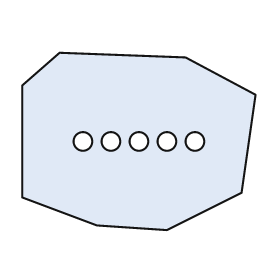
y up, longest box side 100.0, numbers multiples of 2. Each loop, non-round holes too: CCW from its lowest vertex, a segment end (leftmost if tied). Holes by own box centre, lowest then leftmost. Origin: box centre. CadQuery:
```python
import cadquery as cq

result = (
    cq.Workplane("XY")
    .moveTo(12.0, -38.0)
    .lineTo(44.0, -22.0)
    .lineTo(50.0, 20.0)
    .lineTo(20.0, 36.0)
    .lineTo(-34.0, 38.0)
    .lineTo(-50.0, 24.0)
    .lineTo(-50.0, -24.0)
    .lineTo(-18.0, -36.0)
    .close()
    .moveTo(-24.0, 0.0)
    .circle(4.0)
    .moveTo(-12.0, 0.0)
    .circle(4.0)
    .moveTo(0.0, 0.0)
    .circle(4.0)
    .moveTo(12.0, 0.0)
    .circle(4.0)
    .moveTo(24.0, 0.0)
    .circle(4.0)
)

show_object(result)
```